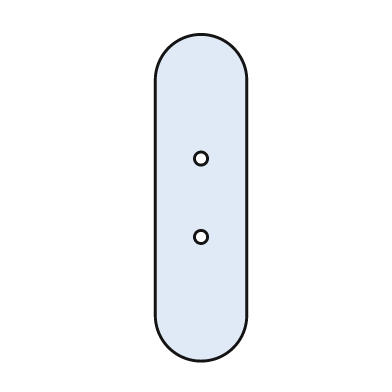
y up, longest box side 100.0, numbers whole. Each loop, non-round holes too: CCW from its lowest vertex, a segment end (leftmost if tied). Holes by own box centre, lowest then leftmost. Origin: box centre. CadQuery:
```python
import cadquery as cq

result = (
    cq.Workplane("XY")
    .moveTo(-14.0, -36.0)
    .threePointArc((0.0, -50.0), (14.0, -36.0))
    .lineTo(14.0, 36.0)
    .threePointArc((0.0, 50.0), (-14.0, 36.0))
    .close()
    .moveTo(0.0, -12.0)
    .circle(2.0)
    .moveTo(0.0, 12.0)
    .circle(2.0)
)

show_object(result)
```